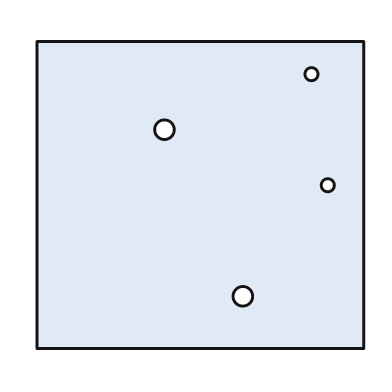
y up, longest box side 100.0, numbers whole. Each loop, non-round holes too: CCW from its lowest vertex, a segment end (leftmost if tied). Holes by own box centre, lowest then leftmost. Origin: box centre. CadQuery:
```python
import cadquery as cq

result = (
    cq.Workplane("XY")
    .moveTo(-50.0, -47.0)
    .lineTo(50.0, -47.0)
    .lineTo(50.0, 47.0)
    .lineTo(-50.0, 47.0)
    .close()
    .moveTo(13.0, -31.0)
    .circle(3.0)
    .moveTo(39.0, 3.0)
    .circle(2.0)
    .moveTo(-11.0, 20.0)
    .circle(3.0)
    .moveTo(34.0, 37.0)
    .circle(2.0)
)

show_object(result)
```